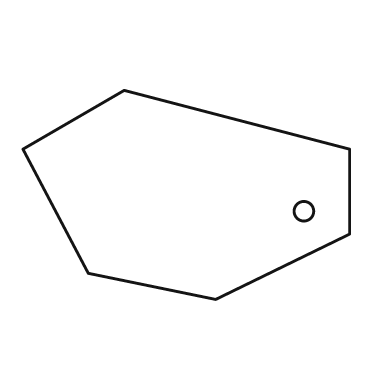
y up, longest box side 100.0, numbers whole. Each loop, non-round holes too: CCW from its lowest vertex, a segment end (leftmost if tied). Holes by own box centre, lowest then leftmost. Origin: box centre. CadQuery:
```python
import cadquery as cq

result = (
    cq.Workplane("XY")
    .moveTo(9.0, -32.0)
    .lineTo(50.0, -12.0)
    .lineTo(50.0, 14.0)
    .lineTo(-19.0, 32.0)
    .lineTo(-50.0, 14.0)
    .lineTo(-30.0, -24.0)
    .close()
    .moveTo(36.0, -5.0)
    .circle(3.0)
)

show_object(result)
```